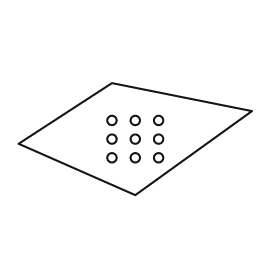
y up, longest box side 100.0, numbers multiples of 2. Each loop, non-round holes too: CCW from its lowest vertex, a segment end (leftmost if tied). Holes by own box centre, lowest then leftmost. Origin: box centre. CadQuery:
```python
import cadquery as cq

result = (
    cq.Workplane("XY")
    .moveTo(0.0, -24.0)
    .lineTo(50.0, 12.0)
    .lineTo(-10.0, 24.0)
    .lineTo(-50.0, -2.0)
    .close()
    .moveTo(-10.0, -8.0)
    .circle(2.0)
    .moveTo(0.0, -8.0)
    .circle(2.0)
    .moveTo(10.0, -8.0)
    .circle(2.0)
    .moveTo(-10.0, 0.0)
    .circle(2.0)
    .moveTo(0.0, 0.0)
    .circle(2.0)
    .moveTo(10.0, 0.0)
    .circle(2.0)
    .moveTo(-10.0, 8.0)
    .circle(2.0)
    .moveTo(0.0, 8.0)
    .circle(2.0)
    .moveTo(10.0, 8.0)
    .circle(2.0)
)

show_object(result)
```